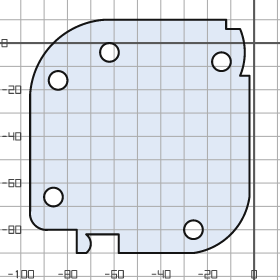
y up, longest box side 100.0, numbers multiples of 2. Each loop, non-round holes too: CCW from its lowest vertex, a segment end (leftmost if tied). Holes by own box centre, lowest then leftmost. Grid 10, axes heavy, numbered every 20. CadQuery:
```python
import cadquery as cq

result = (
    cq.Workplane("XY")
    .moveTo(-76.0, -90.0)
    .lineTo(-72.0, -90.0)
    .threePointArc((-70.0, -86.0), (-72.0, -82.0))
    .lineTo(-58.0, -82.0)
    .lineTo(-58.0, -90.0)
    .lineTo(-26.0, -90.0)
    .threePointArc((-10.0, -82.0), (-2.0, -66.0))
    .lineTo(-2.0, -14.0)
    .lineTo(-6.0, -14.0)
    .threePointArc((-4.0, -4.0), (-6.0, 6.0))
    .lineTo(-12.0, 6.0)
    .lineTo(-12.0, 10.0)
    .lineTo(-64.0, 10.0)
    .threePointArc((-86.0, 0.0), (-96.0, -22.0))
    .lineTo(-96.0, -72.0)
    .threePointArc((-94.0, -78.0), (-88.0, -80.0))
    .lineTo(-76.0, -80.0)
    .close()
    .moveTo(-26.0, -80.0)
    .circle(4.0)
    .moveTo(-86.0, -66.0)
    .circle(4.0)
    .moveTo(-84.0, -16.0)
    .circle(4.0)
    .moveTo(-14.0, -8.0)
    .circle(4.0)
    .moveTo(-62.0, -4.0)
    .circle(4.0)
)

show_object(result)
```